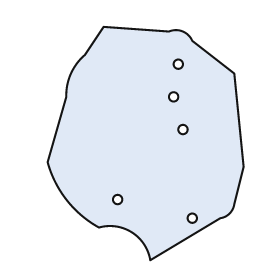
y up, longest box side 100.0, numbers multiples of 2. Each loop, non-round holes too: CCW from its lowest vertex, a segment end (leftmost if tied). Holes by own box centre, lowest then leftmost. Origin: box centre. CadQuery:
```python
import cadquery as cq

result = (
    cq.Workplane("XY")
    .moveTo(2.0, -50.0)
    .lineTo(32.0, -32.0)
    .threePointArc((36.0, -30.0), (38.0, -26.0))
    .lineTo(42.0, -10.0)
    .lineTo(38.0, 30.0)
    .lineTo(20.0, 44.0)
    .threePointArc((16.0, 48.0), (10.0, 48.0))
    .lineTo(-18.0, 50.0)
    .lineTo(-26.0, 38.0)
    .threePointArc((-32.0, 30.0), (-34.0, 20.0))
    .lineTo(-42.0, -8.0)
    .threePointArc((-34.0, -24.0), (-20.0, -36.0))
    .threePointArc((-6.0, -38.0), (2.0, -50.0))
    .close()
    .moveTo(20.0, -32.0)
    .circle(2.0)
    .moveTo(-12.0, -24.0)
    .circle(2.0)
    .moveTo(16.0, 6.0)
    .circle(2.0)
    .moveTo(12.0, 20.0)
    .circle(2.0)
    .moveTo(14.0, 34.0)
    .circle(2.0)
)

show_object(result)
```